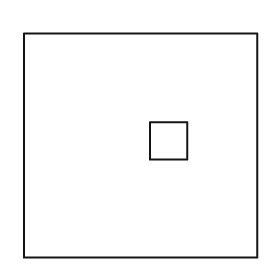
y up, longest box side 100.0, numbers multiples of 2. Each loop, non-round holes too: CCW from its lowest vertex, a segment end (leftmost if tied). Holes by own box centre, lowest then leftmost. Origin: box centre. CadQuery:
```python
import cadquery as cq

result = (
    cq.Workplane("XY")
    .moveTo(-50.0, -48.0)
    .lineTo(50.0, -48.0)
    .lineTo(50.0, 48.0)
    .lineTo(-50.0, 48.0)
    .close()
    .moveTo(4.0, -6.0)
    .lineTo(20.0, -6.0)
    .lineTo(20.0, 10.0)
    .lineTo(4.0, 10.0)
    .close()
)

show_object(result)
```